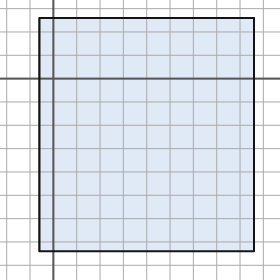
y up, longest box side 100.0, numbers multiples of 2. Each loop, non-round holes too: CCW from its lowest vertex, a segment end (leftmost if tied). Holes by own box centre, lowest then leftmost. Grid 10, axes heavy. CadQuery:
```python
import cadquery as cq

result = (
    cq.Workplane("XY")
    .moveTo(-6.0, -74.0)
    .lineTo(86.0, -74.0)
    .lineTo(86.0, 26.0)
    .lineTo(-6.0, 26.0)
    .close()
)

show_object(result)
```